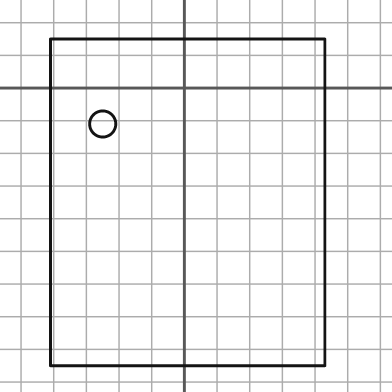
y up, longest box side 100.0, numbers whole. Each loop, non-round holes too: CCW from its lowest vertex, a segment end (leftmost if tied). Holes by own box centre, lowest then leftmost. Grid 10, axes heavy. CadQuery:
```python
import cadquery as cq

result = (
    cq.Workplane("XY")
    .moveTo(-41.0, -85.0)
    .lineTo(43.0, -85.0)
    .lineTo(43.0, 15.0)
    .lineTo(-41.0, 15.0)
    .close()
    .moveTo(-25.0, -11.0)
    .circle(4.0)
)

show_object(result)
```